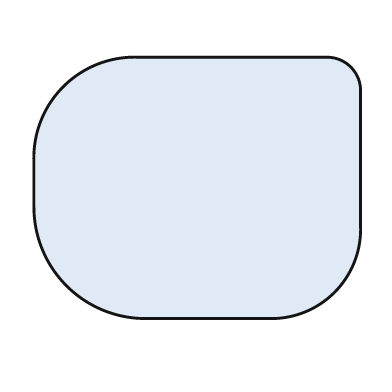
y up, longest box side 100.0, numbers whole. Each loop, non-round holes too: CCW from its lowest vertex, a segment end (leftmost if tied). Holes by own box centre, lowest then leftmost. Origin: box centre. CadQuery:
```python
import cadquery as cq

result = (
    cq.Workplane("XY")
    .moveTo(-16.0, -40.0)
    .lineTo(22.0, -40.0)
    .threePointArc((42.0, -32.0), (50.0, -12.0))
    .lineTo(50.0, 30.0)
    .threePointArc((47.0, 37.0), (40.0, 40.0))
    .lineTo(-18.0, 40.0)
    .threePointArc((-41.0, 31.0), (-50.0, 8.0))
    .lineTo(-50.0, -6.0)
    .threePointArc((-40.0, -30.0), (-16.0, -40.0))
    .close()
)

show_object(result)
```